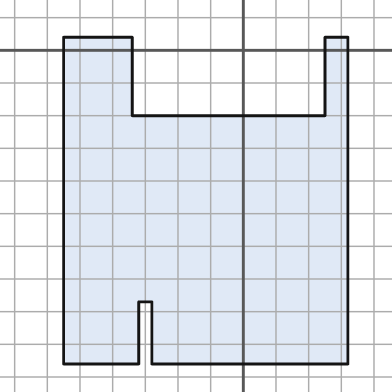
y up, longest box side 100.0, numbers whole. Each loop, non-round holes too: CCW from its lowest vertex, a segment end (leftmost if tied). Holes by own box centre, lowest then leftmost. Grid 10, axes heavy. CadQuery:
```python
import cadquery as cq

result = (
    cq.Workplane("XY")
    .moveTo(-55.0, -96.0)
    .lineTo(-32.0, -96.0)
    .lineTo(-32.0, -77.0)
    .lineTo(-28.0, -77.0)
    .lineTo(-28.0, -96.0)
    .lineTo(32.0, -96.0)
    .lineTo(32.0, 4.0)
    .lineTo(25.0, 4.0)
    .lineTo(25.0, -20.0)
    .lineTo(-34.0, -20.0)
    .lineTo(-34.0, 4.0)
    .lineTo(-55.0, 4.0)
    .close()
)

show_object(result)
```